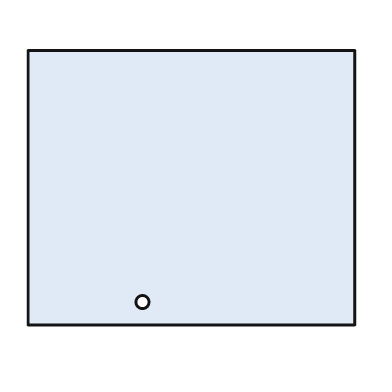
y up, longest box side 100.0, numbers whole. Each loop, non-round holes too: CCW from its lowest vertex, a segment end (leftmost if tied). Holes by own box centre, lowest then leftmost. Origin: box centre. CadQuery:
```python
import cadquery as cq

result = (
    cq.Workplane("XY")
    .moveTo(-50.0, -42.0)
    .lineTo(50.0, -42.0)
    .lineTo(50.0, 42.0)
    .lineTo(-50.0, 42.0)
    .close()
    .moveTo(-15.0, -35.0)
    .circle(2.0)
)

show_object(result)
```